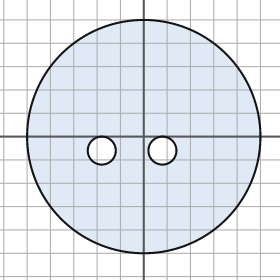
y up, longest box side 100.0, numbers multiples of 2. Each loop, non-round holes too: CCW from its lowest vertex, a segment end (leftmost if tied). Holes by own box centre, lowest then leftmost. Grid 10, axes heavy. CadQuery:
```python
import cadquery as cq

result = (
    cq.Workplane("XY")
    .moveTo(0.0, 0.0)
    .circle(50.0)
    .moveTo(-18.0, -6.0)
    .circle(6.0)
    .moveTo(8.0, -6.0)
    .circle(6.0)
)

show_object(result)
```